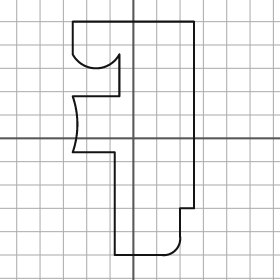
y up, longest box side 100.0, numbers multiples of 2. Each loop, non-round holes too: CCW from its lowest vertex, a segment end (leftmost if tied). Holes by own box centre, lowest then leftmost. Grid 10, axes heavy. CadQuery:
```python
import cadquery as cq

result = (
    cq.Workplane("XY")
    .moveTo(-8.0, -50.0)
    .lineTo(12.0, -50.0)
    .threePointArc((18.0, -48.0), (20.0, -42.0))
    .lineTo(20.0, -30.0)
    .lineTo(26.0, -30.0)
    .lineTo(26.0, 50.0)
    .lineTo(-26.0, 50.0)
    .lineTo(-26.0, 36.0)
    .threePointArc((-16.0, 30.0), (-6.0, 36.0))
    .lineTo(-6.0, 18.0)
    .lineTo(-26.0, 18.0)
    .threePointArc((-24.0, 6.0), (-26.0, -6.0))
    .lineTo(-8.0, -6.0)
    .close()
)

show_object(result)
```